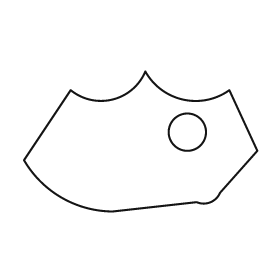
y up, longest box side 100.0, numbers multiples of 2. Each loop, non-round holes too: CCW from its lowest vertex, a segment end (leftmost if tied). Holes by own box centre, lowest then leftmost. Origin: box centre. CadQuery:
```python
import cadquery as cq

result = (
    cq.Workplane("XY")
    .moveTo(-12.0, -30.0)
    .lineTo(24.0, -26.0)
    .threePointArc((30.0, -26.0), (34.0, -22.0))
    .lineTo(50.0, -4.0)
    .lineTo(38.0, 22.0)
    .threePointArc((18.0, 18.0), (2.0, 30.0))
    .threePointArc((-12.0, 18.0), (-30.0, 22.0))
    .lineTo(-50.0, -8.0)
    .threePointArc((-34.0, -24.0), (-12.0, -30.0))
    .close()
    .moveTo(20.0, 4.0)
    .circle(8.0)
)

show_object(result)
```